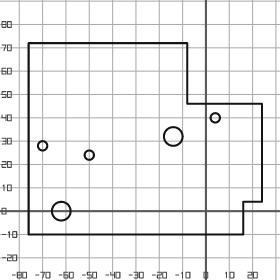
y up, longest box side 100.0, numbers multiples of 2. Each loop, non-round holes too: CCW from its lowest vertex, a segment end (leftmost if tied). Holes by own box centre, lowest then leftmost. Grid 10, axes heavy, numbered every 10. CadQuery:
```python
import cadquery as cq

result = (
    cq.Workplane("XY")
    .moveTo(-76.0, -10.0)
    .lineTo(16.0, -10.0)
    .lineTo(16.0, 4.0)
    .lineTo(24.0, 4.0)
    .lineTo(24.0, 46.0)
    .lineTo(-8.0, 46.0)
    .lineTo(-8.0, 72.0)
    .lineTo(-76.0, 72.0)
    .close()
    .moveTo(-62.0, 0.0)
    .circle(4.0)
    .moveTo(-50.0, 24.0)
    .circle(2.0)
    .moveTo(-70.0, 28.0)
    .circle(2.0)
    .moveTo(-14.0, 32.0)
    .circle(4.0)
    .moveTo(4.0, 40.0)
    .circle(2.0)
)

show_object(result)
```